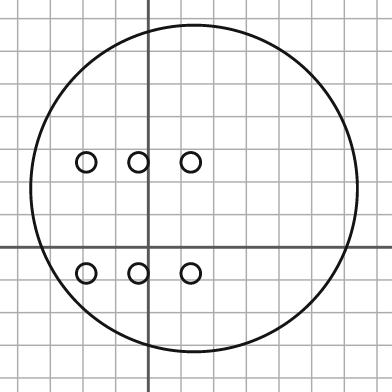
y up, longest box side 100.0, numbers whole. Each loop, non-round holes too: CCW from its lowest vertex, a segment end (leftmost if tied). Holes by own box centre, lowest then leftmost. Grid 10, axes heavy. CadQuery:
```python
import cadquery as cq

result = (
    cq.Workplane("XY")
    .moveTo(14.0, 18.0)
    .circle(50.0)
    .moveTo(-19.0, -8.0)
    .circle(3.0)
    .moveTo(-3.0, -8.0)
    .circle(3.0)
    .moveTo(13.0, -8.0)
    .circle(3.0)
    .moveTo(-19.0, 26.0)
    .circle(3.0)
    .moveTo(-3.0, 26.0)
    .circle(3.0)
    .moveTo(13.0, 26.0)
    .circle(3.0)
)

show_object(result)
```